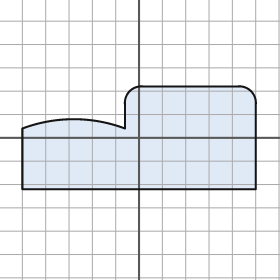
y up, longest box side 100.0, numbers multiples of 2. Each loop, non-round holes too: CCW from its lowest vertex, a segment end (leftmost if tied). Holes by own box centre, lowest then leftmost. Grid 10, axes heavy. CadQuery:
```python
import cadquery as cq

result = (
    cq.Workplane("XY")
    .moveTo(-50.0, -22.0)
    .lineTo(50.0, -22.0)
    .lineTo(50.0, 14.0)
    .threePointArc((48.0, 20.0), (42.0, 22.0))
    .lineTo(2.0, 22.0)
    .threePointArc((-4.0, 20.0), (-6.0, 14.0))
    .lineTo(-6.0, 4.0)
    .threePointArc((-28.0, 8.0), (-50.0, 4.0))
    .close()
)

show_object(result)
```